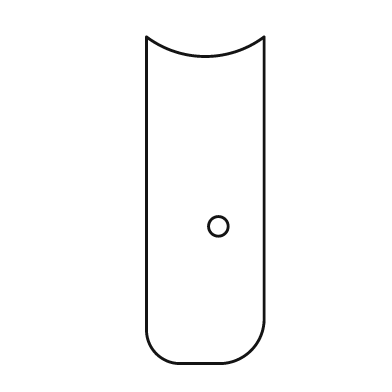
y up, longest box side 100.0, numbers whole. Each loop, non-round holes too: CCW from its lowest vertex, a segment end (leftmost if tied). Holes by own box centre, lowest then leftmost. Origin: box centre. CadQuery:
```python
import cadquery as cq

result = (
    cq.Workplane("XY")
    .moveTo(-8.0, -50.0)
    .lineTo(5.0, -50.0)
    .threePointArc((14.0, -46.0), (18.0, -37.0))
    .lineTo(18.0, 50.0)
    .threePointArc((0.0, 44.0), (-18.0, 50.0))
    .lineTo(-18.0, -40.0)
    .threePointArc((-15.0, -47.0), (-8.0, -50.0))
    .close()
    .moveTo(4.0, -8.0)
    .circle(3.0)
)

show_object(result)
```